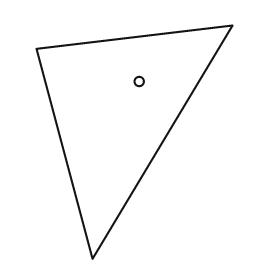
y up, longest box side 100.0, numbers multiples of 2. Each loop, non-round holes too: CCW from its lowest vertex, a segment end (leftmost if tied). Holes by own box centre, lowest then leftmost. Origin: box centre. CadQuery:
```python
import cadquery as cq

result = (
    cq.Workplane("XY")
    .moveTo(-18.0, -50.0)
    .lineTo(42.0, 50.0)
    .lineTo(-42.0, 40.0)
    .close()
    .moveTo(2.0, 26.0)
    .circle(2.0)
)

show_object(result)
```